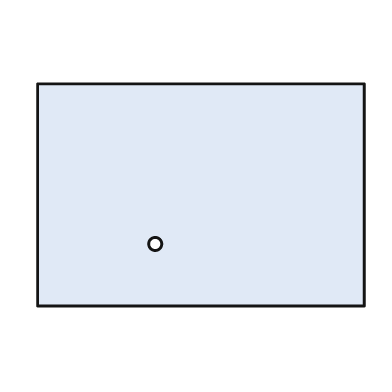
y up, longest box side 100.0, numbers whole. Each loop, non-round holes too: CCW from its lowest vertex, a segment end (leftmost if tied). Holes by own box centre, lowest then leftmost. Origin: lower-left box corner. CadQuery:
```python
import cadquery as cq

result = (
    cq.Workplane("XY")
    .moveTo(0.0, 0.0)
    .lineTo(100.0, 0.0)
    .lineTo(100.0, 68.0)
    .lineTo(0.0, 68.0)
    .close()
    .moveTo(36.0, 19.0)
    .circle(2.0)
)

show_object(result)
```